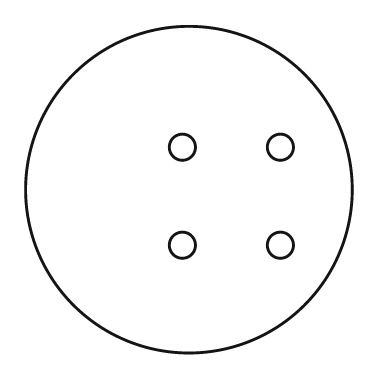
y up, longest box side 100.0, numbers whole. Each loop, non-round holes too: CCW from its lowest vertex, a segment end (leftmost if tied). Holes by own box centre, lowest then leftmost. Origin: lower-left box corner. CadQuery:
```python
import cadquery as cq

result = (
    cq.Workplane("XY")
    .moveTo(50.0, 50.0)
    .circle(50.0)
    .moveTo(48.0, 33.0)
    .circle(4.0)
    .moveTo(78.0, 33.0)
    .circle(4.0)
    .moveTo(48.0, 63.0)
    .circle(4.0)
    .moveTo(78.0, 63.0)
    .circle(4.0)
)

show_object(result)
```